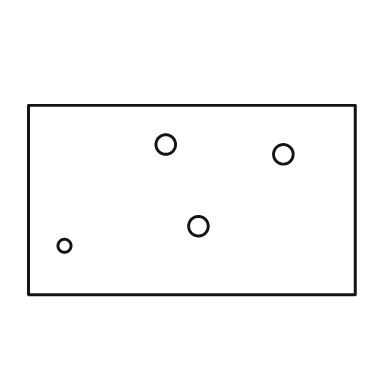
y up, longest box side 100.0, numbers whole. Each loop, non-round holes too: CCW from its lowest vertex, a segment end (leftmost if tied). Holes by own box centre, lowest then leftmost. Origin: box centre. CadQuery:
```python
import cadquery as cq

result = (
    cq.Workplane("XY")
    .moveTo(-50.0, -29.0)
    .lineTo(50.0, -29.0)
    .lineTo(50.0, 29.0)
    .lineTo(-50.0, 29.0)
    .close()
    .moveTo(-39.0, -14.0)
    .circle(2.0)
    .moveTo(2.0, -8.0)
    .circle(3.0)
    .moveTo(28.0, 14.0)
    .circle(3.0)
    .moveTo(-8.0, 17.0)
    .circle(3.0)
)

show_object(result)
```